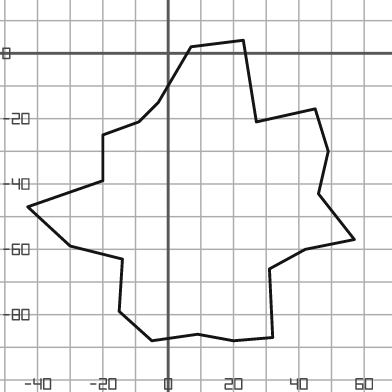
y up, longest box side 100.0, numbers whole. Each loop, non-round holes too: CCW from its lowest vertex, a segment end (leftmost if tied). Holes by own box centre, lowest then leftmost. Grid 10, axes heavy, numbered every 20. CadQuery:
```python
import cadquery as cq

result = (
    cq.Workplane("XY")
    .moveTo(-5.0, -88.0)
    .lineTo(9.0, -86.0)
    .lineTo(20.0, -88.0)
    .lineTo(32.0, -87.0)
    .lineTo(31.0, -66.0)
    .lineTo(42.0, -60.0)
    .lineTo(57.0, -57.0)
    .lineTo(46.0, -43.0)
    .lineTo(49.0, -30.0)
    .lineTo(45.0, -17.0)
    .lineTo(27.0, -21.0)
    .lineTo(23.0, 4.0)
    .lineTo(7.0, 2.0)
    .lineTo(-3.0, -15.0)
    .lineTo(-9.0, -21.0)
    .lineTo(-20.0, -25.0)
    .lineTo(-20.0, -39.0)
    .lineTo(-43.0, -47.0)
    .lineTo(-30.0, -59.0)
    .lineTo(-14.0, -63.0)
    .lineTo(-15.0, -79.0)
    .close()
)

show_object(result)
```